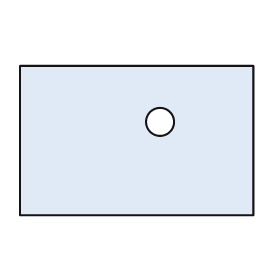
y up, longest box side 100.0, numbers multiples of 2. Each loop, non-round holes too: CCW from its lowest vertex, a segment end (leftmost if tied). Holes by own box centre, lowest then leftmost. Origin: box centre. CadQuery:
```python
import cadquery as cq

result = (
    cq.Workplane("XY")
    .moveTo(-50.0, -32.0)
    .lineTo(50.0, -32.0)
    .lineTo(50.0, 32.0)
    .lineTo(-50.0, 32.0)
    .close()
    .moveTo(10.0, 8.0)
    .circle(6.0)
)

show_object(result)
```